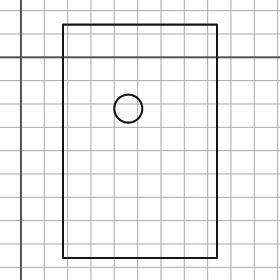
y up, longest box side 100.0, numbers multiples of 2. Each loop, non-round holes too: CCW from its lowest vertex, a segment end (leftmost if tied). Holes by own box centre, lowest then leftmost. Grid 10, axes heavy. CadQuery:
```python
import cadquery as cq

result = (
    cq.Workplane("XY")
    .moveTo(18.0, -86.0)
    .lineTo(84.0, -86.0)
    .lineTo(84.0, 14.0)
    .lineTo(18.0, 14.0)
    .close()
    .moveTo(46.0, -22.0)
    .circle(6.0)
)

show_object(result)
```